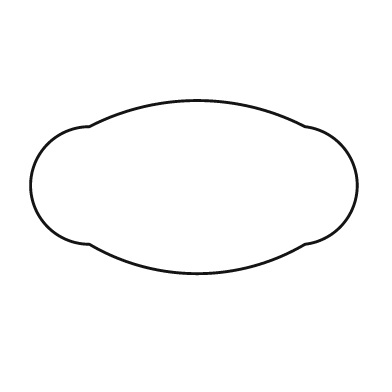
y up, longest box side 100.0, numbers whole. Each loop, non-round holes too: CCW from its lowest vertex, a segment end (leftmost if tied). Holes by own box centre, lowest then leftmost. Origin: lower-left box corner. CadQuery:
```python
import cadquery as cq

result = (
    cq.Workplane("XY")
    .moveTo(18.0, 9.0)
    .threePointArc((51.0, 0.0), (84.0, 9.0))
    .threePointArc((100.0, 27.0), (84.0, 45.0))
    .threePointArc((51.0, 53.0), (18.0, 45.0))
    .threePointArc((0.0, 27.0), (18.0, 9.0))
    .close()
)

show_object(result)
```